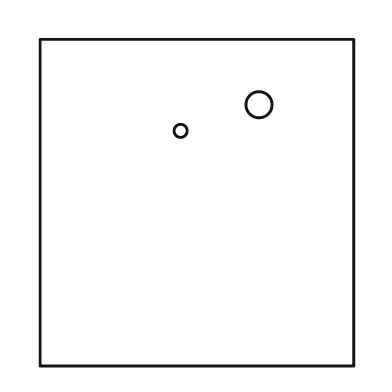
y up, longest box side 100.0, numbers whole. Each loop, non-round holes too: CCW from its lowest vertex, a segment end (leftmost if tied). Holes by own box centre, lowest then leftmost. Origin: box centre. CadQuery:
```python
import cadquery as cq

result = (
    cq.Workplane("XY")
    .moveTo(-48.0, -50.0)
    .lineTo(48.0, -50.0)
    .lineTo(48.0, 50.0)
    .lineTo(-48.0, 50.0)
    .close()
    .moveTo(-5.0, 22.0)
    .circle(2.0)
    .moveTo(19.0, 30.0)
    .circle(4.0)
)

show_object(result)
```